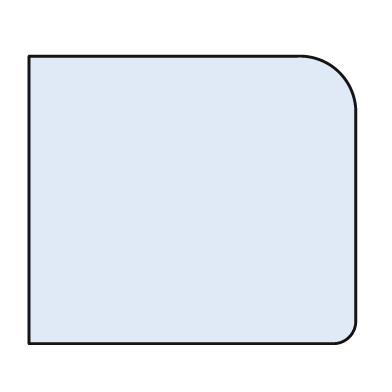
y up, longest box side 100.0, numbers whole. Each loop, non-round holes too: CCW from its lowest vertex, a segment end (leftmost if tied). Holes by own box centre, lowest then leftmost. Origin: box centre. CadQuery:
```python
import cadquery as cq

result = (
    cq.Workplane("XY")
    .moveTo(-50.0, -44.0)
    .lineTo(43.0, -44.0)
    .threePointArc((48.0, -42.0), (50.0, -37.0))
    .lineTo(50.0, 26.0)
    .threePointArc((45.0, 39.0), (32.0, 44.0))
    .lineTo(-50.0, 44.0)
    .close()
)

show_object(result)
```